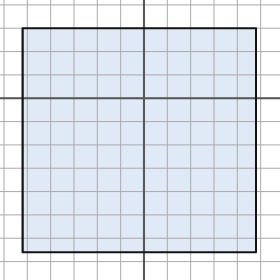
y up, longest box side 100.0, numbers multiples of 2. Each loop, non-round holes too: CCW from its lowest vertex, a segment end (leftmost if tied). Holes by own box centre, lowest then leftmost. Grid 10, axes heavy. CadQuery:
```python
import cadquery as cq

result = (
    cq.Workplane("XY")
    .moveTo(-52.0, -66.0)
    .lineTo(48.0, -66.0)
    .lineTo(48.0, 30.0)
    .lineTo(-52.0, 30.0)
    .close()
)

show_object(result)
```